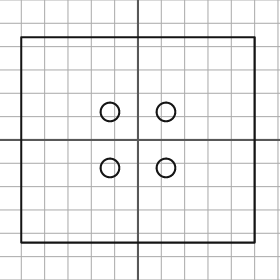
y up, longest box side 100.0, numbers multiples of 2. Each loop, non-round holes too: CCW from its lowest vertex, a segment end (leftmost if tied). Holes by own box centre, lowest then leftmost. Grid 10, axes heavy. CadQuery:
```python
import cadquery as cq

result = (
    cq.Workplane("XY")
    .moveTo(-50.0, -44.0)
    .lineTo(50.0, -44.0)
    .lineTo(50.0, 44.0)
    .lineTo(-50.0, 44.0)
    .close()
    .moveTo(-12.0, -12.0)
    .circle(4.0)
    .moveTo(12.0, -12.0)
    .circle(4.0)
    .moveTo(-12.0, 12.0)
    .circle(4.0)
    .moveTo(12.0, 12.0)
    .circle(4.0)
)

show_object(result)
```